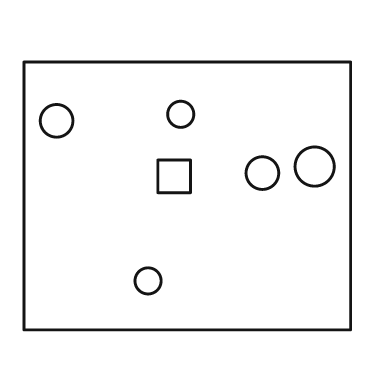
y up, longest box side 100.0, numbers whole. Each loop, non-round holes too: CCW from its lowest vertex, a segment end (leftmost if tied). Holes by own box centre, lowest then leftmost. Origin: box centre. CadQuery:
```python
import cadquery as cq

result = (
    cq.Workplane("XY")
    .moveTo(-50.0, -41.0)
    .lineTo(50.0, -41.0)
    .lineTo(50.0, 41.0)
    .lineTo(-50.0, 41.0)
    .close()
    .moveTo(-12.0, -26.0)
    .circle(4.0)
    .moveTo(-9.0, 1.0)
    .lineTo(1.0, 1.0)
    .lineTo(1.0, 11.0)
    .lineTo(-9.0, 11.0)
    .close()
    .moveTo(23.0, 7.0)
    .circle(5.0)
    .moveTo(39.0, 9.0)
    .circle(6.0)
    .moveTo(-40.0, 23.0)
    .circle(5.0)
    .moveTo(-2.0, 25.0)
    .circle(4.0)
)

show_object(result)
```